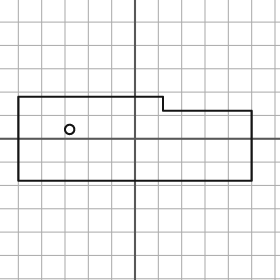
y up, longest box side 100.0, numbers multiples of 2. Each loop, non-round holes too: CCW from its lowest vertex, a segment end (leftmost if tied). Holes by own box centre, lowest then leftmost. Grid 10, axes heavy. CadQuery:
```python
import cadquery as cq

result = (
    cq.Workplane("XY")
    .moveTo(-50.0, -18.0)
    .lineTo(50.0, -18.0)
    .lineTo(50.0, 12.0)
    .lineTo(12.0, 12.0)
    .lineTo(12.0, 18.0)
    .lineTo(-50.0, 18.0)
    .close()
    .moveTo(-28.0, 4.0)
    .circle(2.0)
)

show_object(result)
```